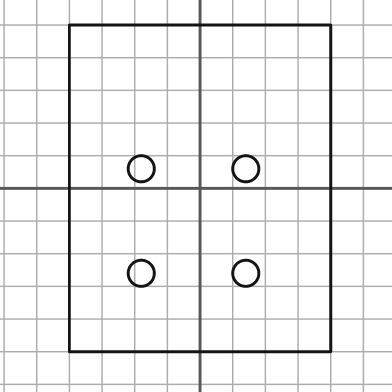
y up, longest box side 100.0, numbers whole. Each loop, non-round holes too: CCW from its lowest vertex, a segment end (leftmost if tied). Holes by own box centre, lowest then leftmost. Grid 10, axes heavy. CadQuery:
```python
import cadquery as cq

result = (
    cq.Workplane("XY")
    .moveTo(-40.0, -50.0)
    .lineTo(40.0, -50.0)
    .lineTo(40.0, 50.0)
    .lineTo(-40.0, 50.0)
    .close()
    .moveTo(-18.0, -26.0)
    .circle(4.0)
    .moveTo(14.0, -26.0)
    .circle(4.0)
    .moveTo(-18.0, 6.0)
    .circle(4.0)
    .moveTo(14.0, 6.0)
    .circle(4.0)
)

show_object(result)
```